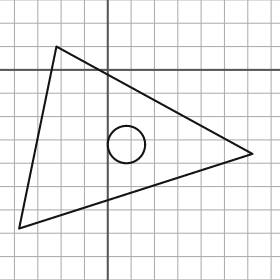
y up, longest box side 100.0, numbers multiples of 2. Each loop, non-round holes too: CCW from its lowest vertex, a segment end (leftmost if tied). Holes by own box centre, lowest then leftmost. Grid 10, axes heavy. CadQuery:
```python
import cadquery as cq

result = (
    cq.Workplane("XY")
    .moveTo(-38.0, -68.0)
    .lineTo(62.0, -36.0)
    .lineTo(-22.0, 10.0)
    .close()
    .moveTo(8.0, -32.0)
    .circle(8.0)
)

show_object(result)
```